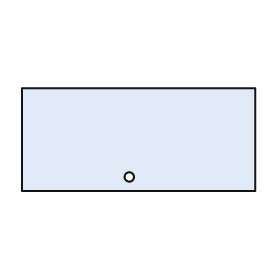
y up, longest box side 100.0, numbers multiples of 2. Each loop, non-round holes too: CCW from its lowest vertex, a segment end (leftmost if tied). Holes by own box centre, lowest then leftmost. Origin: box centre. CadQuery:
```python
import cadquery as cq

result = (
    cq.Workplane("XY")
    .moveTo(-50.0, -22.0)
    .lineTo(50.0, -22.0)
    .lineTo(50.0, 22.0)
    .lineTo(-50.0, 22.0)
    .close()
    .moveTo(-4.0, -16.0)
    .circle(2.0)
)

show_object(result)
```